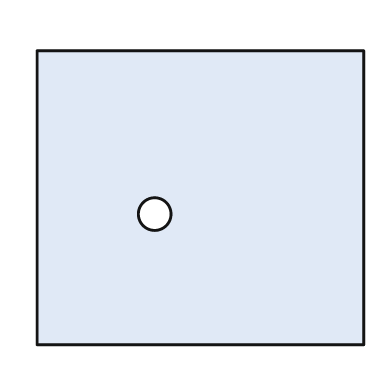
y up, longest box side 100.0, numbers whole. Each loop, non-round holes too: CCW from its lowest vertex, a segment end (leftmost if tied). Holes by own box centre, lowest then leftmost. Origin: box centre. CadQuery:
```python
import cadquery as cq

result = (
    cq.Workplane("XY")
    .moveTo(-50.0, -45.0)
    .lineTo(50.0, -45.0)
    .lineTo(50.0, 45.0)
    .lineTo(-50.0, 45.0)
    .close()
    .moveTo(-14.0, -5.0)
    .circle(5.0)
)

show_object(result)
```